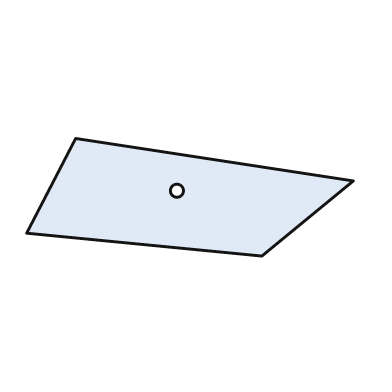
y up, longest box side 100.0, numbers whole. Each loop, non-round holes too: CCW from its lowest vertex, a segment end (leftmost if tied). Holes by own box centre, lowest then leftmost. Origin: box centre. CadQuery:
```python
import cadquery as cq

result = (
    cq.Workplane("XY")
    .moveTo(22.0, -18.0)
    .lineTo(50.0, 5.0)
    .lineTo(-35.0, 18.0)
    .lineTo(-50.0, -11.0)
    .close()
    .moveTo(-4.0, 2.0)
    .circle(2.0)
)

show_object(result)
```